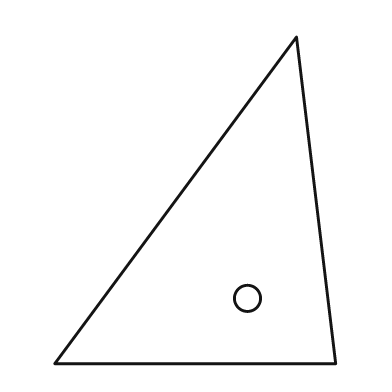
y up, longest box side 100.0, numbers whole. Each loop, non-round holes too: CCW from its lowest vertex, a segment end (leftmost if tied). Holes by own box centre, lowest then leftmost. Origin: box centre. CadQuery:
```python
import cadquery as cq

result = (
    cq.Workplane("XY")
    .moveTo(-43.0, -50.0)
    .lineTo(43.0, -50.0)
    .lineTo(31.0, 50.0)
    .close()
    .moveTo(16.0, -30.0)
    .circle(4.0)
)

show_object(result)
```